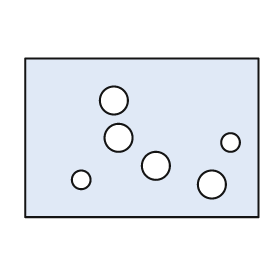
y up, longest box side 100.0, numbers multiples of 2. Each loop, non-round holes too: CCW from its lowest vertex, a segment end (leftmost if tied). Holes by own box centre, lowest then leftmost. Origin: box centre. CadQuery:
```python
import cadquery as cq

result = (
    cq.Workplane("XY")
    .moveTo(-50.0, -34.0)
    .lineTo(50.0, -34.0)
    .lineTo(50.0, 34.0)
    .lineTo(-50.0, 34.0)
    .close()
    .moveTo(30.0, -20.0)
    .circle(6.0)
    .moveTo(-26.0, -18.0)
    .circle(4.0)
    .moveTo(6.0, -12.0)
    .circle(6.0)
    .moveTo(38.0, -2.0)
    .circle(4.0)
    .moveTo(-10.0, 0.0)
    .circle(6.0)
    .moveTo(-12.0, 16.0)
    .circle(6.0)
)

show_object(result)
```